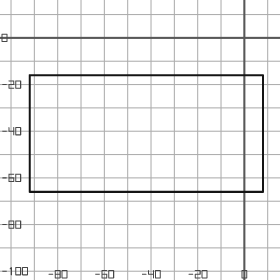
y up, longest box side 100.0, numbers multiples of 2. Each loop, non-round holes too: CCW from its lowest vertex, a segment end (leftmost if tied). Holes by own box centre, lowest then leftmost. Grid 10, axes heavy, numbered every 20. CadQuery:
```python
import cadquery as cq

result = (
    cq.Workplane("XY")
    .moveTo(-92.0, -66.0)
    .lineTo(8.0, -66.0)
    .lineTo(8.0, -16.0)
    .lineTo(-92.0, -16.0)
    .close()
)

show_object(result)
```